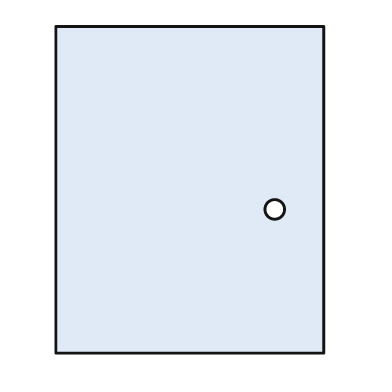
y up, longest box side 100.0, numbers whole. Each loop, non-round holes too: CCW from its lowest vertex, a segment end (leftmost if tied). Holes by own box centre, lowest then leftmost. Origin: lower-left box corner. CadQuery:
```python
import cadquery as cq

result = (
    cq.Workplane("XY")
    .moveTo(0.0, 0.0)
    .lineTo(82.0, 0.0)
    .lineTo(82.0, 100.0)
    .lineTo(0.0, 100.0)
    .close()
    .moveTo(67.0, 44.0)
    .circle(3.0)
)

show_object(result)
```